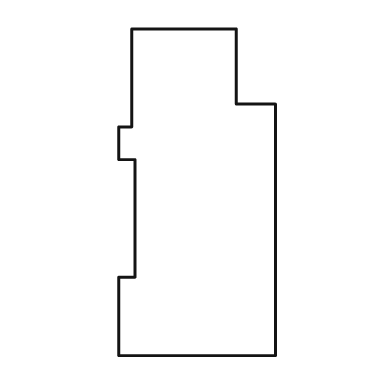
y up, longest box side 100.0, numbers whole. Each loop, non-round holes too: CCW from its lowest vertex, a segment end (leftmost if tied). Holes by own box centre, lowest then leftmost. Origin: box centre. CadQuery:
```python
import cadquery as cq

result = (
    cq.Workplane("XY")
    .moveTo(-24.0, -50.0)
    .lineTo(24.0, -50.0)
    .lineTo(24.0, 27.0)
    .lineTo(12.0, 27.0)
    .lineTo(12.0, 50.0)
    .lineTo(-20.0, 50.0)
    .lineTo(-20.0, 20.0)
    .lineTo(-24.0, 20.0)
    .lineTo(-24.0, 10.0)
    .lineTo(-19.0, 10.0)
    .lineTo(-19.0, -26.0)
    .lineTo(-24.0, -26.0)
    .close()
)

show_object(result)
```